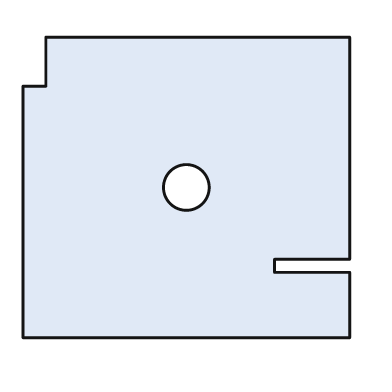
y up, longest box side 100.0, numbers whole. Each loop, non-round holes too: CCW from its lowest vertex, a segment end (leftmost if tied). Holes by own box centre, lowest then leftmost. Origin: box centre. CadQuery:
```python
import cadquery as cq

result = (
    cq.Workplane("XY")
    .moveTo(-50.0, -46.0)
    .lineTo(50.0, -46.0)
    .lineTo(50.0, -26.0)
    .lineTo(27.0, -26.0)
    .lineTo(27.0, -22.0)
    .lineTo(50.0, -22.0)
    .lineTo(50.0, 46.0)
    .lineTo(-43.0, 46.0)
    .lineTo(-43.0, 31.0)
    .lineTo(-50.0, 31.0)
    .close()
    .moveTo(0.0, 0.0)
    .circle(7.0)
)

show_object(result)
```